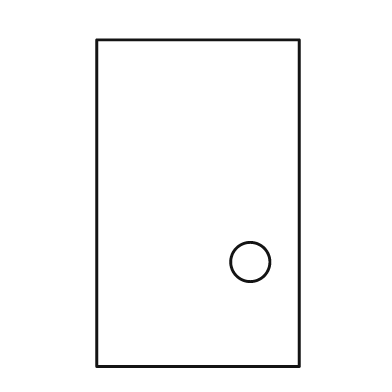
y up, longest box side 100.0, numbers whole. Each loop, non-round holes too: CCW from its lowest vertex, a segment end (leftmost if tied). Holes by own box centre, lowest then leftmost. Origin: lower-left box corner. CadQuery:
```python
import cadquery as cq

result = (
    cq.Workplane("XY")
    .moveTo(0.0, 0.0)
    .lineTo(62.0, 0.0)
    .lineTo(62.0, 100.0)
    .lineTo(0.0, 100.0)
    .close()
    .moveTo(47.0, 32.0)
    .circle(6.0)
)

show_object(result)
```